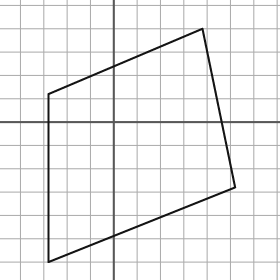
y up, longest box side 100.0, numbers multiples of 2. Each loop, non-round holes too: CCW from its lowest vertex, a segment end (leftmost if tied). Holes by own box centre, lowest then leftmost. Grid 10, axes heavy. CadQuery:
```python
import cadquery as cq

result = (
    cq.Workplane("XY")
    .moveTo(-28.0, -60.0)
    .lineTo(52.0, -28.0)
    .lineTo(38.0, 40.0)
    .lineTo(-28.0, 12.0)
    .close()
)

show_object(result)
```